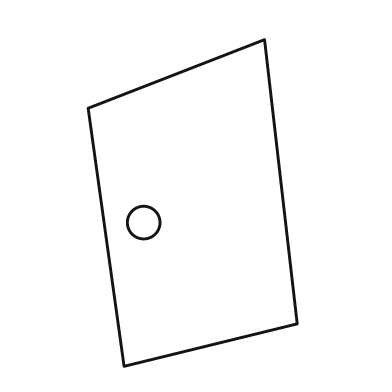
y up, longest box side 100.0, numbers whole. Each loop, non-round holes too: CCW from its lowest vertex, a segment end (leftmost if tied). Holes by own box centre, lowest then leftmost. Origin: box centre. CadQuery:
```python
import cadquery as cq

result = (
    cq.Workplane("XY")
    .moveTo(-21.0, -50.0)
    .lineTo(32.0, -37.0)
    .lineTo(22.0, 50.0)
    .lineTo(-32.0, 29.0)
    .close()
    .moveTo(-15.0, -6.0)
    .circle(5.0)
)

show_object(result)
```